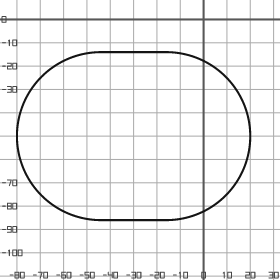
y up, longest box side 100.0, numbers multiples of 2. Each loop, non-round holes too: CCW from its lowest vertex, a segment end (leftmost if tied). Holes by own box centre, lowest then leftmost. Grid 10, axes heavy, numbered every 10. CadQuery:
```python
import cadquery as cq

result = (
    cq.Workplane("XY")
    .moveTo(-44.0, -86.0)
    .lineTo(-16.0, -86.0)
    .threePointArc((20.0, -50.0), (-16.0, -14.0))
    .lineTo(-44.0, -14.0)
    .threePointArc((-80.0, -50.0), (-44.0, -86.0))
    .close()
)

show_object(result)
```